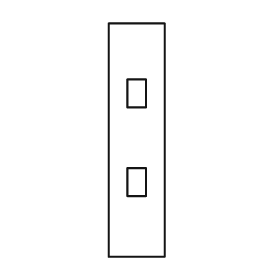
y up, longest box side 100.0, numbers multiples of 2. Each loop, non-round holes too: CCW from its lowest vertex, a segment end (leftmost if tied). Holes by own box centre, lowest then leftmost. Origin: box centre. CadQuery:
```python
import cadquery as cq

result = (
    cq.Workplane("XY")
    .moveTo(-12.0, -50.0)
    .lineTo(12.0, -50.0)
    .lineTo(12.0, 50.0)
    .lineTo(-12.0, 50.0)
    .close()
    .moveTo(-4.0, -24.0)
    .lineTo(4.0, -24.0)
    .lineTo(4.0, -12.0)
    .lineTo(-4.0, -12.0)
    .close()
    .moveTo(-4.0, 14.0)
    .lineTo(4.0, 14.0)
    .lineTo(4.0, 26.0)
    .lineTo(-4.0, 26.0)
    .close()
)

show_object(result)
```